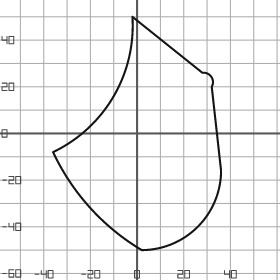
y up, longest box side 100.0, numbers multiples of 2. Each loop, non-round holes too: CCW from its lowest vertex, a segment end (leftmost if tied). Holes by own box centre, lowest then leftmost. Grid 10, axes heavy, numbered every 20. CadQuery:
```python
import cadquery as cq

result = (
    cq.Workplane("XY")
    .moveTo(2.0, -50.0)
    .threePointArc((26.0, -40.0), (36.0, -16.0))
    .lineTo(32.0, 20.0)
    .threePointArc((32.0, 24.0), (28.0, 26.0))
    .lineTo(-2.0, 50.0)
    .threePointArc((-10.0, 16.0), (-36.0, -8.0))
    .threePointArc((-20.0, -32.0), (2.0, -50.0))
    .close()
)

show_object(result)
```